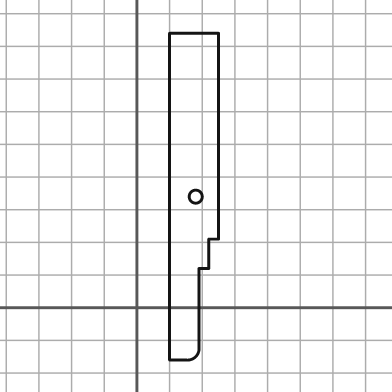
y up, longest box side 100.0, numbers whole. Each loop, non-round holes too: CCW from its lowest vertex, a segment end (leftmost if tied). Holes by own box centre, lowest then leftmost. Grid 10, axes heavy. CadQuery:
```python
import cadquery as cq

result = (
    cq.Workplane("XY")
    .moveTo(10.0, -16.0)
    .lineTo(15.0, -16.0)
    .threePointArc((18.0, -15.0), (19.0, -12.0))
    .lineTo(19.0, 12.0)
    .lineTo(22.0, 12.0)
    .lineTo(22.0, 21.0)
    .lineTo(25.0, 21.0)
    .lineTo(25.0, 84.0)
    .lineTo(10.0, 84.0)
    .close()
    .moveTo(18.0, 34.0)
    .circle(2.0)
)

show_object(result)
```